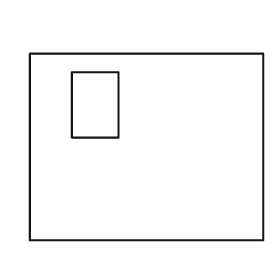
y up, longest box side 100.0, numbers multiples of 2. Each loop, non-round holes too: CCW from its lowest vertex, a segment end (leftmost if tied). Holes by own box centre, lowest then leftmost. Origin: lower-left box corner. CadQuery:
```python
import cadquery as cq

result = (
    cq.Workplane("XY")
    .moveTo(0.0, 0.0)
    .lineTo(100.0, 0.0)
    .lineTo(100.0, 80.0)
    .lineTo(0.0, 80.0)
    .close()
    .moveTo(18.0, 44.0)
    .lineTo(38.0, 44.0)
    .lineTo(38.0, 72.0)
    .lineTo(18.0, 72.0)
    .close()
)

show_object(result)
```